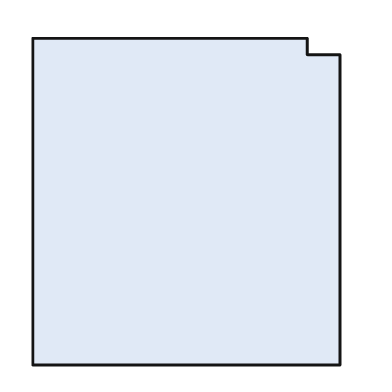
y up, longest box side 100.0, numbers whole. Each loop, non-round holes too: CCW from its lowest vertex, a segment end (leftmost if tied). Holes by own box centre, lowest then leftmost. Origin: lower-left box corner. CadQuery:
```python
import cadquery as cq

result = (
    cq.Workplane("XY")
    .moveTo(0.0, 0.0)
    .lineTo(94.0, 0.0)
    .lineTo(94.0, 95.0)
    .lineTo(84.0, 95.0)
    .lineTo(84.0, 100.0)
    .lineTo(0.0, 100.0)
    .close()
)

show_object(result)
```